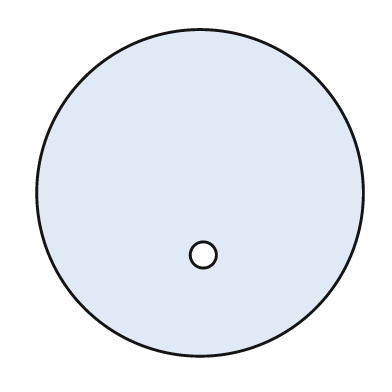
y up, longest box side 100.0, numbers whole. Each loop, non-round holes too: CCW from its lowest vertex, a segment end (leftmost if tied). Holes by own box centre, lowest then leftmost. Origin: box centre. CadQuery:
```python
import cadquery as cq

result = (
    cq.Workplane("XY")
    .moveTo(0.0, 0.0)
    .circle(50.0)
    .moveTo(1.0, -19.0)
    .circle(4.0)
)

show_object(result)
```